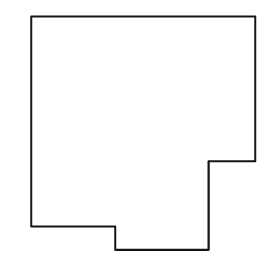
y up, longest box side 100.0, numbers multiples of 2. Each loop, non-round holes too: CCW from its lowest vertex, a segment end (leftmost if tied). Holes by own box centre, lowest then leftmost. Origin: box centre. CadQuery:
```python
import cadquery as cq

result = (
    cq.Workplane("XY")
    .moveTo(-12.0, -50.0)
    .lineTo(28.0, -50.0)
    .lineTo(28.0, -12.0)
    .lineTo(48.0, -12.0)
    .lineTo(48.0, 50.0)
    .lineTo(-48.0, 50.0)
    .lineTo(-48.0, -40.0)
    .lineTo(-12.0, -40.0)
    .close()
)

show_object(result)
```